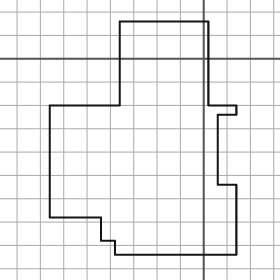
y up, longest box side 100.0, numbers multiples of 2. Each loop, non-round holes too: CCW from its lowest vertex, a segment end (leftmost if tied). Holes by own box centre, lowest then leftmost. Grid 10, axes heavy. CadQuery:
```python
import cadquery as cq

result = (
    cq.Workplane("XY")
    .moveTo(-38.0, -84.0)
    .lineTo(14.0, -84.0)
    .lineTo(14.0, -54.0)
    .lineTo(6.0, -54.0)
    .lineTo(6.0, -24.0)
    .lineTo(14.0, -24.0)
    .lineTo(14.0, -20.0)
    .lineTo(2.0, -20.0)
    .lineTo(2.0, 16.0)
    .lineTo(-36.0, 16.0)
    .lineTo(-36.0, -20.0)
    .lineTo(-66.0, -20.0)
    .lineTo(-66.0, -68.0)
    .lineTo(-44.0, -68.0)
    .lineTo(-44.0, -78.0)
    .lineTo(-38.0, -78.0)
    .close()
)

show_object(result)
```